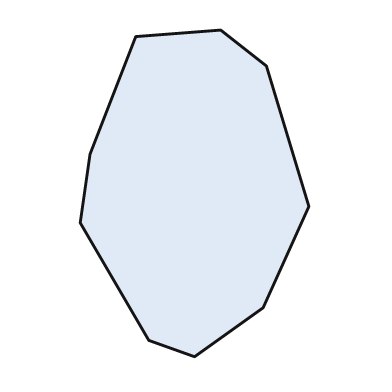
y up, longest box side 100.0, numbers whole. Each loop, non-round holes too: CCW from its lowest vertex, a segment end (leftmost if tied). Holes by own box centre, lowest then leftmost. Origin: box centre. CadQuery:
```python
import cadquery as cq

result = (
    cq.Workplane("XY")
    .moveTo(0.0, -50.0)
    .lineTo(21.0, -35.0)
    .lineTo(35.0, -4.0)
    .lineTo(22.0, 39.0)
    .lineTo(8.0, 50.0)
    .lineTo(-18.0, 48.0)
    .lineTo(-32.0, 12.0)
    .lineTo(-35.0, -9.0)
    .lineTo(-14.0, -45.0)
    .close()
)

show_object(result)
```